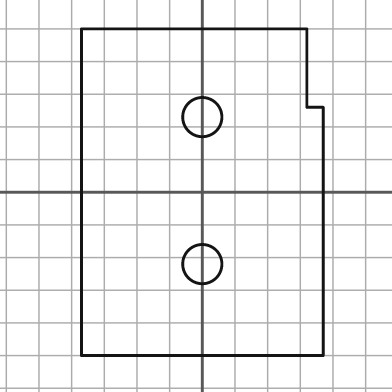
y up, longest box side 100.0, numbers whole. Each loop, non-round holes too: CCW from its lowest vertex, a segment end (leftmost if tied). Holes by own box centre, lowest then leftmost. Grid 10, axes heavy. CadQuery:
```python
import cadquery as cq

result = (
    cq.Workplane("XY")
    .moveTo(-37.0, -50.0)
    .lineTo(37.0, -50.0)
    .lineTo(37.0, 26.0)
    .lineTo(32.0, 26.0)
    .lineTo(32.0, 50.0)
    .lineTo(-37.0, 50.0)
    .close()
    .moveTo(0.0, -22.0)
    .circle(6.0)
    .moveTo(0.0, 23.0)
    .circle(6.0)
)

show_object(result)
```